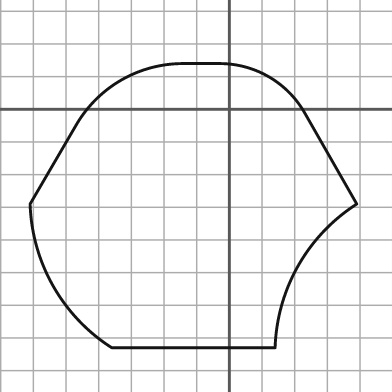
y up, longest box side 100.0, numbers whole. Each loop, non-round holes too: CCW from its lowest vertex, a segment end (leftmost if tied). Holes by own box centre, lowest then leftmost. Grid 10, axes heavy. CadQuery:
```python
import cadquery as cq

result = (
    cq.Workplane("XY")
    .moveTo(-36.0, -73.0)
    .lineTo(14.0, -73.0)
    .threePointArc((21.0, -48.0), (39.0, -29.0))
    .lineTo(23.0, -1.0)
    .threePointArc((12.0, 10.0), (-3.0, 14.0))
    .lineTo(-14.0, 14.0)
    .threePointArc((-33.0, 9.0), (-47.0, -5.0))
    .lineTo(-61.0, -29.0)
    .threePointArc((-54.0, -54.0), (-36.0, -73.0))
    .close()
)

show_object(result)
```